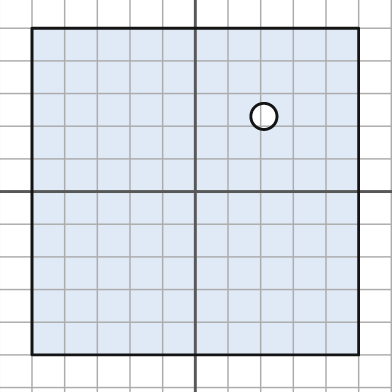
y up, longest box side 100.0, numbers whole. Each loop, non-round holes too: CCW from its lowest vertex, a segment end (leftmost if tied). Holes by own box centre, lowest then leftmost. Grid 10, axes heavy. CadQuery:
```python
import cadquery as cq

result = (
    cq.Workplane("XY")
    .moveTo(-50.0, -50.0)
    .lineTo(50.0, -50.0)
    .lineTo(50.0, 50.0)
    .lineTo(-50.0, 50.0)
    .close()
    .moveTo(21.0, 23.0)
    .circle(4.0)
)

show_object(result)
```